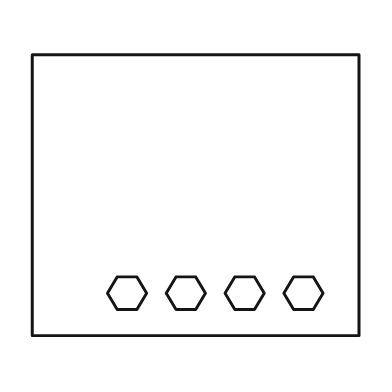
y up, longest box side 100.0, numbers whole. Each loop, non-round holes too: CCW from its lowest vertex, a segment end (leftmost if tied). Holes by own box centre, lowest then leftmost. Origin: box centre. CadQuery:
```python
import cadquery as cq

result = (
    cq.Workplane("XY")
    .moveTo(-50.0, -43.0)
    .lineTo(50.0, -43.0)
    .lineTo(50.0, 43.0)
    .lineTo(-50.0, 43.0)
    .close()
    .moveTo(-24.0, -35.0)
    .lineTo(-18.0, -35.0)
    .lineTo(-15.0, -30.0)
    .lineTo(-18.0, -25.0)
    .lineTo(-24.0, -25.0)
    .lineTo(-27.0, -30.0)
    .close()
    .moveTo(-6.0, -35.0)
    .lineTo(0.0, -35.0)
    .lineTo(3.0, -30.0)
    .lineTo(0.0, -25.0)
    .lineTo(-6.0, -25.0)
    .lineTo(-9.0, -30.0)
    .close()
    .moveTo(12.0, -35.0)
    .lineTo(18.0, -35.0)
    .lineTo(21.0, -30.0)
    .lineTo(18.0, -25.0)
    .lineTo(12.0, -25.0)
    .lineTo(9.0, -30.0)
    .close()
    .moveTo(30.0, -35.0)
    .lineTo(36.0, -35.0)
    .lineTo(39.0, -30.0)
    .lineTo(36.0, -25.0)
    .lineTo(30.0, -25.0)
    .lineTo(27.0, -30.0)
    .close()
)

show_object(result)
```